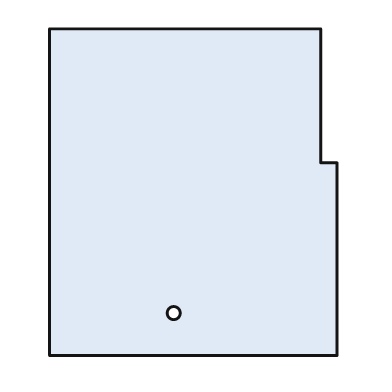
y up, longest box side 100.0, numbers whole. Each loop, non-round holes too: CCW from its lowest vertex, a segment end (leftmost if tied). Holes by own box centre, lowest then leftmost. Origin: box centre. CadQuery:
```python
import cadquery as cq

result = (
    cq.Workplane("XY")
    .moveTo(-44.0, -50.0)
    .lineTo(44.0, -50.0)
    .lineTo(44.0, 9.0)
    .lineTo(39.0, 9.0)
    .lineTo(39.0, 50.0)
    .lineTo(-44.0, 50.0)
    .close()
    .moveTo(-6.0, -37.0)
    .circle(2.0)
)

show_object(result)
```